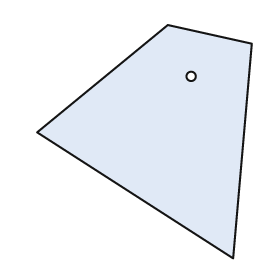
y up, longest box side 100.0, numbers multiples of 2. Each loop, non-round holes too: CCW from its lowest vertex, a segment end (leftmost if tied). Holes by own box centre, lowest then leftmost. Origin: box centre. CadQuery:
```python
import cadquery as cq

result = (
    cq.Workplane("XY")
    .moveTo(38.0, -50.0)
    .lineTo(46.0, 42.0)
    .lineTo(10.0, 50.0)
    .lineTo(-46.0, 4.0)
    .close()
    .moveTo(20.0, 28.0)
    .circle(2.0)
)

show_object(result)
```